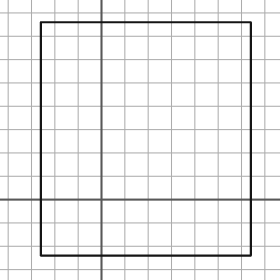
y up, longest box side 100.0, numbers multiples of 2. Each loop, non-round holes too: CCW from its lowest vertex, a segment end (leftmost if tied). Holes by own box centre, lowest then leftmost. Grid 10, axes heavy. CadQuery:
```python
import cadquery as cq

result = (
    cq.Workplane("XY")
    .moveTo(-26.0, -24.0)
    .lineTo(64.0, -24.0)
    .lineTo(64.0, 76.0)
    .lineTo(-26.0, 76.0)
    .close()
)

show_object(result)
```